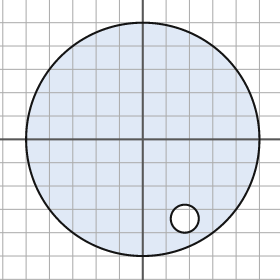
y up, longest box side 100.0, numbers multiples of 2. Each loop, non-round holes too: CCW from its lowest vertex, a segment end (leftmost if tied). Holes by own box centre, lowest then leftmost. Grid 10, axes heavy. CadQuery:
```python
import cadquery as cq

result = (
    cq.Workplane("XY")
    .moveTo(0.0, 0.0)
    .circle(50.0)
    .moveTo(18.0, -34.0)
    .circle(6.0)
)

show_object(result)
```